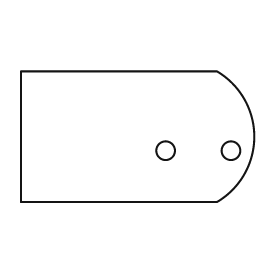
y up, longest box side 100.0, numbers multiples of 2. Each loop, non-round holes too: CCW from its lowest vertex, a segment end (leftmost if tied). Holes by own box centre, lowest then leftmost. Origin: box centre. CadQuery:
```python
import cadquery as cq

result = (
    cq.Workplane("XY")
    .moveTo(-50.0, -28.0)
    .lineTo(34.0, -28.0)
    .threePointArc((50.0, 0.0), (34.0, 28.0))
    .lineTo(-50.0, 28.0)
    .close()
    .moveTo(12.0, -6.0)
    .circle(4.0)
    .moveTo(40.0, -6.0)
    .circle(4.0)
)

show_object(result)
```